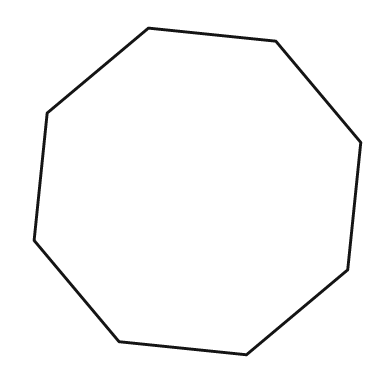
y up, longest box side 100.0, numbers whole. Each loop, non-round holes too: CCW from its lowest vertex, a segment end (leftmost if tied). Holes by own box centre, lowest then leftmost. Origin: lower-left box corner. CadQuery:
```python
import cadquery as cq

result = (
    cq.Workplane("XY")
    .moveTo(65.0, 0.0)
    .lineTo(96.0, 26.0)
    .lineTo(100.0, 65.0)
    .lineTo(74.0, 96.0)
    .lineTo(35.0, 100.0)
    .lineTo(4.0, 74.0)
    .lineTo(0.0, 35.0)
    .lineTo(26.0, 4.0)
    .close()
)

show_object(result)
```